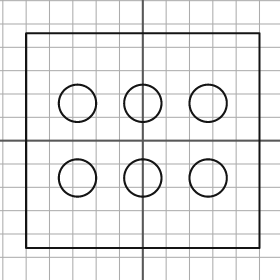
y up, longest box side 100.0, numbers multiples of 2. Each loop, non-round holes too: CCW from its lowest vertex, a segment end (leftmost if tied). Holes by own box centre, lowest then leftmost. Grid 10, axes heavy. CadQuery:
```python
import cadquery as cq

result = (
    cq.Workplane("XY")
    .moveTo(-50.0, -46.0)
    .lineTo(50.0, -46.0)
    .lineTo(50.0, 46.0)
    .lineTo(-50.0, 46.0)
    .close()
    .moveTo(-28.0, -16.0)
    .circle(8.0)
    .moveTo(0.0, -16.0)
    .circle(8.0)
    .moveTo(28.0, -16.0)
    .circle(8.0)
    .moveTo(-28.0, 16.0)
    .circle(8.0)
    .moveTo(0.0, 16.0)
    .circle(8.0)
    .moveTo(28.0, 16.0)
    .circle(8.0)
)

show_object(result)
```